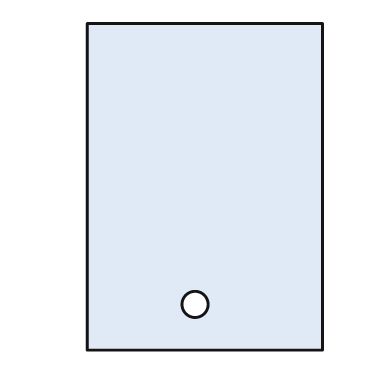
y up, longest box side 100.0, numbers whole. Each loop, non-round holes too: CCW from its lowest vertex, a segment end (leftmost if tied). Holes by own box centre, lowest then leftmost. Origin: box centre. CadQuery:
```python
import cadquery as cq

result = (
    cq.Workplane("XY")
    .moveTo(-36.0, -50.0)
    .lineTo(36.0, -50.0)
    .lineTo(36.0, 50.0)
    .lineTo(-36.0, 50.0)
    .close()
    .moveTo(-3.0, -36.0)
    .circle(4.0)
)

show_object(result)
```